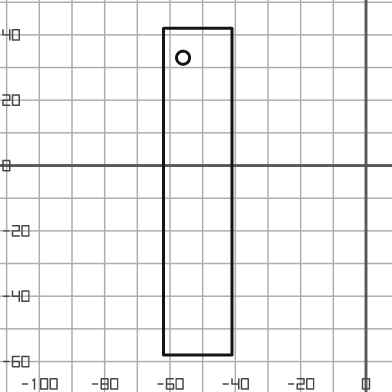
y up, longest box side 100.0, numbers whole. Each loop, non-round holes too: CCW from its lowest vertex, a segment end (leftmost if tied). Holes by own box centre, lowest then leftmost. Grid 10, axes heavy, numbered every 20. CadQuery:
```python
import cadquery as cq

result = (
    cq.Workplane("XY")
    .moveTo(-62.0, -58.0)
    .lineTo(-41.0, -58.0)
    .lineTo(-41.0, 42.0)
    .lineTo(-62.0, 42.0)
    .close()
    .moveTo(-56.0, 33.0)
    .circle(2.0)
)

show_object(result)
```